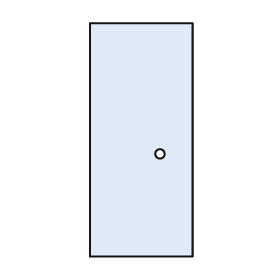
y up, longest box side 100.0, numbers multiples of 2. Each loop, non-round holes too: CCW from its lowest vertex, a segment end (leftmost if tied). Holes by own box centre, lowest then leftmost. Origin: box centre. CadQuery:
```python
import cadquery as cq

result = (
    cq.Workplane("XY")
    .moveTo(-22.0, -50.0)
    .lineTo(22.0, -50.0)
    .lineTo(22.0, 50.0)
    .lineTo(-22.0, 50.0)
    .close()
    .moveTo(8.0, -6.0)
    .circle(2.0)
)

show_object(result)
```